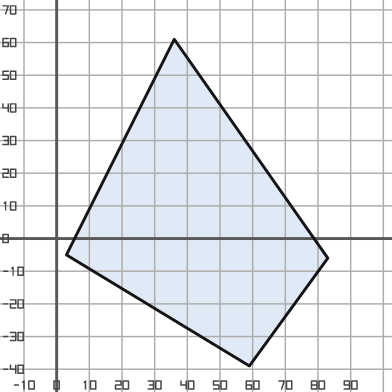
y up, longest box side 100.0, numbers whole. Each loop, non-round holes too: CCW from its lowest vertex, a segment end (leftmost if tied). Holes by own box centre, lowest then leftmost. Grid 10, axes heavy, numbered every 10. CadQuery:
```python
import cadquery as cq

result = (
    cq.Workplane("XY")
    .moveTo(59.0, -39.0)
    .lineTo(83.0, -6.0)
    .lineTo(36.0, 61.0)
    .lineTo(3.0, -5.0)
    .close()
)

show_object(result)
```